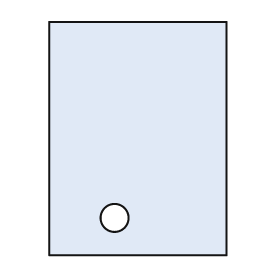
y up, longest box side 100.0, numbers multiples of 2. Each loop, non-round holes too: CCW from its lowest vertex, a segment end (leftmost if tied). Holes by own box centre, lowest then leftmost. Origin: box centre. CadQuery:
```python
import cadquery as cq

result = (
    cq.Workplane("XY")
    .moveTo(-38.0, -50.0)
    .lineTo(38.0, -50.0)
    .lineTo(38.0, 50.0)
    .lineTo(-38.0, 50.0)
    .close()
    .moveTo(-10.0, -34.0)
    .circle(6.0)
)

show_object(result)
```